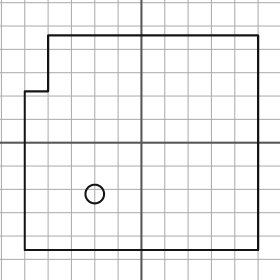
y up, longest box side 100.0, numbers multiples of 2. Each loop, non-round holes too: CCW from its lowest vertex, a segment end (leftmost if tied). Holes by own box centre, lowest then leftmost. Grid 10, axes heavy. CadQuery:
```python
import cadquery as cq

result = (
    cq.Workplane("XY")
    .moveTo(-50.0, -46.0)
    .lineTo(50.0, -46.0)
    .lineTo(50.0, 46.0)
    .lineTo(-40.0, 46.0)
    .lineTo(-40.0, 22.0)
    .lineTo(-50.0, 22.0)
    .close()
    .moveTo(-20.0, -22.0)
    .circle(4.0)
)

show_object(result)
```